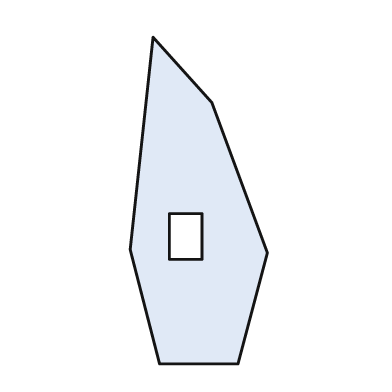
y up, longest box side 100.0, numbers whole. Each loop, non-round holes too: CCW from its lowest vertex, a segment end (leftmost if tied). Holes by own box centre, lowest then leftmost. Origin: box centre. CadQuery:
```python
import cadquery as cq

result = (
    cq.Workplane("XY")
    .moveTo(-12.0, -50.0)
    .lineTo(12.0, -50.0)
    .lineTo(21.0, -16.0)
    .lineTo(4.0, 30.0)
    .lineTo(-14.0, 50.0)
    .lineTo(-21.0, -15.0)
    .close()
    .moveTo(-9.0, -18.0)
    .lineTo(1.0, -18.0)
    .lineTo(1.0, -4.0)
    .lineTo(-9.0, -4.0)
    .close()
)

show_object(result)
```